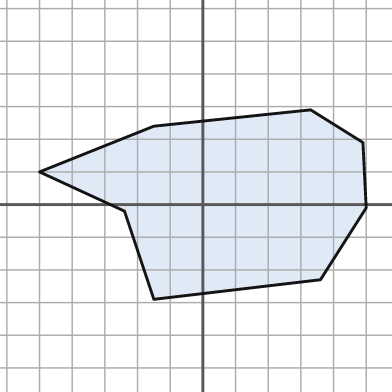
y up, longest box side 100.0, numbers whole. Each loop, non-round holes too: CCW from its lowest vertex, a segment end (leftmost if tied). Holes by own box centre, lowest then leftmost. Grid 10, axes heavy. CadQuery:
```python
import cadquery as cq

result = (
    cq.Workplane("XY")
    .moveTo(-15.0, -29.0)
    .lineTo(36.0, -23.0)
    .lineTo(50.0, -1.0)
    .lineTo(49.0, 19.0)
    .lineTo(33.0, 29.0)
    .lineTo(-15.0, 24.0)
    .lineTo(-50.0, 10.0)
    .lineTo(-24.0, -2.0)
    .close()
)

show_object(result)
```